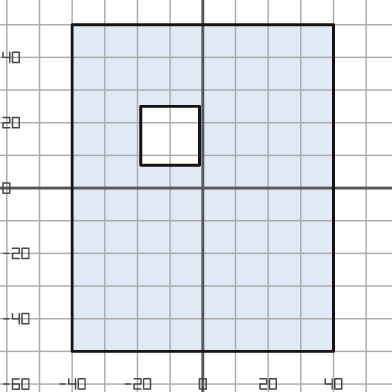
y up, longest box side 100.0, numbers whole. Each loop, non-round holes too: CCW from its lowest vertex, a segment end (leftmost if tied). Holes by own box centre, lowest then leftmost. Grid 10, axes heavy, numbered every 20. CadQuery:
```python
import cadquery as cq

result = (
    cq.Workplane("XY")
    .moveTo(-40.0, -50.0)
    .lineTo(40.0, -50.0)
    .lineTo(40.0, 50.0)
    .lineTo(-40.0, 50.0)
    .close()
    .moveTo(-19.0, 7.0)
    .lineTo(-1.0, 7.0)
    .lineTo(-1.0, 25.0)
    .lineTo(-19.0, 25.0)
    .close()
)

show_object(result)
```